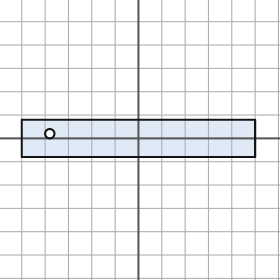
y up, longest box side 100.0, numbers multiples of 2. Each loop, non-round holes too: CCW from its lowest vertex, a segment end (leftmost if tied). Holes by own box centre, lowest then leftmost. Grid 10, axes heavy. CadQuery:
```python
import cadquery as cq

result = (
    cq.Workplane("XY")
    .moveTo(-50.0, -8.0)
    .lineTo(50.0, -8.0)
    .lineTo(50.0, 8.0)
    .lineTo(-50.0, 8.0)
    .close()
    .moveTo(-38.0, 2.0)
    .circle(2.0)
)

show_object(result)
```